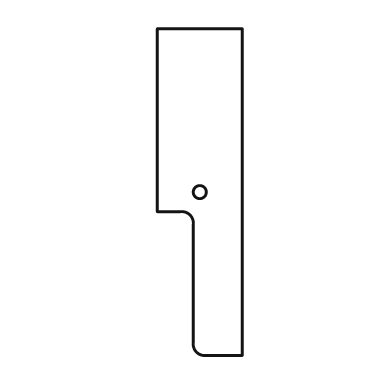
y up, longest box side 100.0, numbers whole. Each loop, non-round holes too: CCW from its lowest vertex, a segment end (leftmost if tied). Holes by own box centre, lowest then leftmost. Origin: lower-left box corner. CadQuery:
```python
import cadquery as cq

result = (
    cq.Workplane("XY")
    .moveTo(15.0, 0.0)
    .lineTo(26.0, 0.0)
    .lineTo(26.0, 100.0)
    .lineTo(0.0, 100.0)
    .lineTo(0.0, 44.0)
    .lineTo(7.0, 44.0)
    .threePointArc((10.0, 43.0), (11.0, 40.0))
    .lineTo(11.0, 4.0)
    .threePointArc((12.0, 1.0), (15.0, 0.0))
    .close()
    .moveTo(13.0, 50.0)
    .circle(2.0)
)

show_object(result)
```